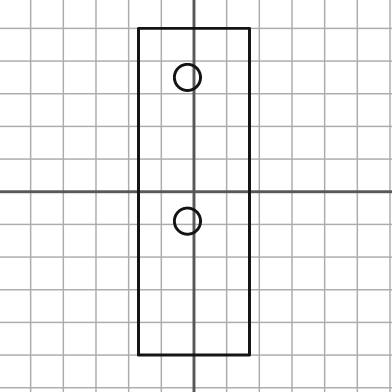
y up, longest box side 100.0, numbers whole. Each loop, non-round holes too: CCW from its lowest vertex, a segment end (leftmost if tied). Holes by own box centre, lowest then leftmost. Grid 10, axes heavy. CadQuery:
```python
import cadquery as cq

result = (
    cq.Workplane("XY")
    .moveTo(-17.0, -50.0)
    .lineTo(17.0, -50.0)
    .lineTo(17.0, 50.0)
    .lineTo(-17.0, 50.0)
    .close()
    .moveTo(-2.0, -9.0)
    .circle(4.0)
    .moveTo(-2.0, 35.0)
    .circle(4.0)
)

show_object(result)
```